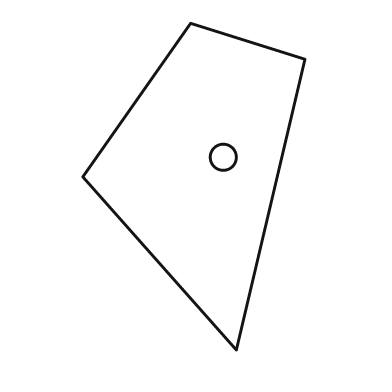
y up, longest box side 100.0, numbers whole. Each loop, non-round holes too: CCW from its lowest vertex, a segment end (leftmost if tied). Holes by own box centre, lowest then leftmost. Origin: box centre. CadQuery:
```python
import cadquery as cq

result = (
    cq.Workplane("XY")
    .moveTo(13.0, -50.0)
    .lineTo(34.0, 39.0)
    .lineTo(-1.0, 50.0)
    .lineTo(-34.0, 3.0)
    .close()
    .moveTo(9.0, 9.0)
    .circle(4.0)
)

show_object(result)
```